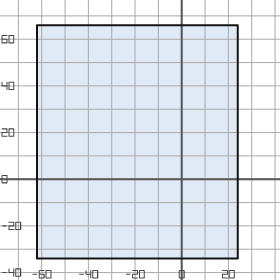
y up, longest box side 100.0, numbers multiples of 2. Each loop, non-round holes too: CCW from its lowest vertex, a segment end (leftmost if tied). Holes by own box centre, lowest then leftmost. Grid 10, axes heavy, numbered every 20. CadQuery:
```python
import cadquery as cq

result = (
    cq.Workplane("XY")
    .moveTo(-62.0, -34.0)
    .lineTo(24.0, -34.0)
    .lineTo(24.0, 66.0)
    .lineTo(-62.0, 66.0)
    .close()
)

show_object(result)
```